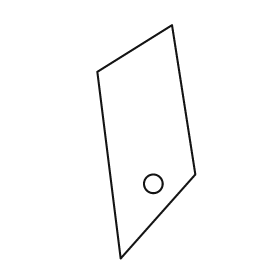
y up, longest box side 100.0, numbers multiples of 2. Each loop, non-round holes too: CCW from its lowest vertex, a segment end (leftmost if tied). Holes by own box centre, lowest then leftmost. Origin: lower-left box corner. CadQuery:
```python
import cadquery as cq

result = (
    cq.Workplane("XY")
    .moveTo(10.0, 0.0)
    .lineTo(42.0, 36.0)
    .lineTo(32.0, 100.0)
    .lineTo(0.0, 80.0)
    .close()
    .moveTo(24.0, 32.0)
    .circle(4.0)
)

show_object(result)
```